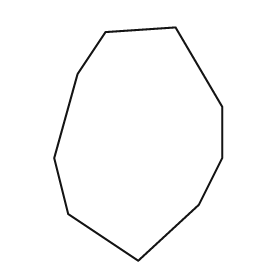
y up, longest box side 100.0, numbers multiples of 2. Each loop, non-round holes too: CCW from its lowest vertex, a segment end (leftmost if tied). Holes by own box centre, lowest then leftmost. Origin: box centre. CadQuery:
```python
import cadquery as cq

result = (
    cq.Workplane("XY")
    .moveTo(0.0, -50.0)
    .lineTo(26.0, -26.0)
    .lineTo(36.0, -6.0)
    .lineTo(36.0, 16.0)
    .lineTo(16.0, 50.0)
    .lineTo(-14.0, 48.0)
    .lineTo(-26.0, 30.0)
    .lineTo(-36.0, -6.0)
    .lineTo(-30.0, -30.0)
    .close()
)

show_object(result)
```